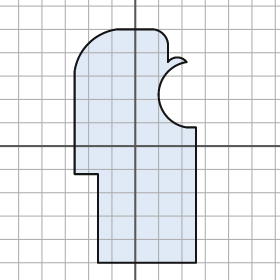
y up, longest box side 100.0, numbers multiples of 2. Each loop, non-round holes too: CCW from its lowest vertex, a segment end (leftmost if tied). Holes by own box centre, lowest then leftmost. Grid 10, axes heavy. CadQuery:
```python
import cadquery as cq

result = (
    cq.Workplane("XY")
    .moveTo(-16.0, -50.0)
    .lineTo(26.0, -50.0)
    .lineTo(26.0, 8.0)
    .lineTo(22.0, 8.0)
    .threePointArc((10.0, 22.0), (22.0, 36.0))
    .threePointArc((18.0, 38.0), (14.0, 36.0))
    .lineTo(14.0, 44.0)
    .threePointArc((12.0, 48.0), (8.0, 50.0))
    .lineTo(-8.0, 50.0)
    .threePointArc((-20.0, 44.0), (-26.0, 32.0))
    .lineTo(-26.0, -12.0)
    .lineTo(-16.0, -12.0)
    .close()
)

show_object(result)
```